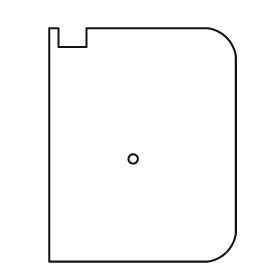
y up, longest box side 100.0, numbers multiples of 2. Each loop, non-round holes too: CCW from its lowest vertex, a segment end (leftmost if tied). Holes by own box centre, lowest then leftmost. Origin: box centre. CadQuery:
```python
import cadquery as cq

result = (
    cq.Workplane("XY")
    .moveTo(-40.0, -50.0)
    .lineTo(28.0, -50.0)
    .threePointArc((36.0, -46.0), (40.0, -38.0))
    .lineTo(40.0, 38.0)
    .threePointArc((36.0, 46.0), (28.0, 50.0))
    .lineTo(-24.0, 50.0)
    .lineTo(-24.0, 42.0)
    .lineTo(-36.0, 42.0)
    .lineTo(-36.0, 50.0)
    .lineTo(-40.0, 50.0)
    .close()
    .moveTo(-4.0, -6.0)
    .circle(2.0)
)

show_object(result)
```